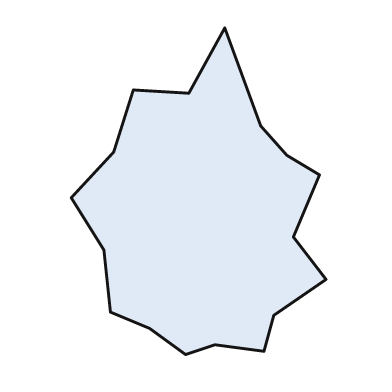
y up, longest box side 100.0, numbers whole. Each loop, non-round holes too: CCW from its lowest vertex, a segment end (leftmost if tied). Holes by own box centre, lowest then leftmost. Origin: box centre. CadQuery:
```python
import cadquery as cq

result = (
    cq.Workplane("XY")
    .moveTo(-4.0, -50.0)
    .lineTo(5.0, -47.0)
    .lineTo(20.0, -49.0)
    .lineTo(23.0, -38.0)
    .lineTo(39.0, -27.0)
    .lineTo(29.0, -14.0)
    .lineTo(37.0, 5.0)
    .lineTo(27.0, 11.0)
    .lineTo(19.0, 20.0)
    .lineTo(8.0, 50.0)
    .lineTo(-3.0, 30.0)
    .lineTo(-20.0, 31.0)
    .lineTo(-26.0, 12.0)
    .lineTo(-39.0, -2.0)
    .lineTo(-29.0, -18.0)
    .lineTo(-27.0, -37.0)
    .lineTo(-15.0, -42.0)
    .close()
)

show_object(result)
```